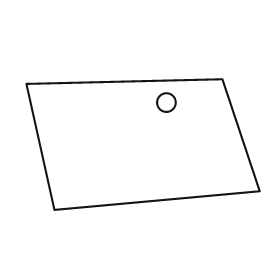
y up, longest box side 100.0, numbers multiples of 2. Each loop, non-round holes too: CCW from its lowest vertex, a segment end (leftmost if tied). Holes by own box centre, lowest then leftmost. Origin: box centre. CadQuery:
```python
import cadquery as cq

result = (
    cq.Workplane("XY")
    .moveTo(-38.0, -28.0)
    .lineTo(50.0, -20.0)
    .lineTo(34.0, 28.0)
    .lineTo(-50.0, 26.0)
    .close()
    .moveTo(10.0, 18.0)
    .circle(4.0)
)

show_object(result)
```